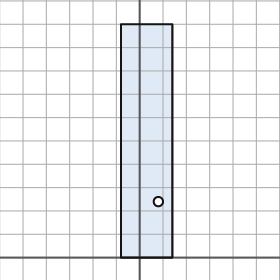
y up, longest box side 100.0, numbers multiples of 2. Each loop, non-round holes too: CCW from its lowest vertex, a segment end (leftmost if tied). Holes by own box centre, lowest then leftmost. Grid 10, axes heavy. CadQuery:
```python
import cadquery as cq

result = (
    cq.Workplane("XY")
    .moveTo(-8.0, 0.0)
    .lineTo(14.0, 0.0)
    .lineTo(14.0, 100.0)
    .lineTo(-8.0, 100.0)
    .close()
    .moveTo(8.0, 24.0)
    .circle(2.0)
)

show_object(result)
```